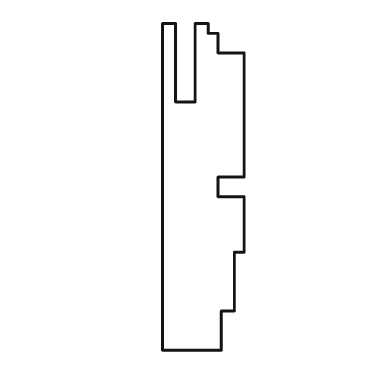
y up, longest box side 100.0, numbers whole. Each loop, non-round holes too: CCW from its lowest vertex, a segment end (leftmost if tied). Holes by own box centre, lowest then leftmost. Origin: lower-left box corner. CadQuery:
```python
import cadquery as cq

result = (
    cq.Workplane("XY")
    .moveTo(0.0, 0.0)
    .lineTo(18.0, 0.0)
    .lineTo(18.0, 12.0)
    .lineTo(22.0, 12.0)
    .lineTo(22.0, 30.0)
    .lineTo(25.0, 30.0)
    .lineTo(25.0, 47.0)
    .lineTo(17.0, 47.0)
    .lineTo(17.0, 53.0)
    .lineTo(25.0, 53.0)
    .lineTo(25.0, 91.0)
    .lineTo(17.0, 91.0)
    .lineTo(17.0, 97.0)
    .lineTo(14.0, 97.0)
    .lineTo(14.0, 100.0)
    .lineTo(10.0, 100.0)
    .lineTo(10.0, 76.0)
    .lineTo(4.0, 76.0)
    .lineTo(4.0, 100.0)
    .lineTo(0.0, 100.0)
    .close()
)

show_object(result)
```